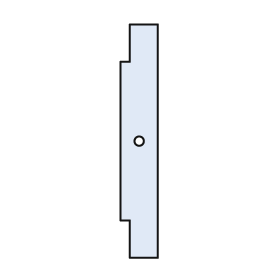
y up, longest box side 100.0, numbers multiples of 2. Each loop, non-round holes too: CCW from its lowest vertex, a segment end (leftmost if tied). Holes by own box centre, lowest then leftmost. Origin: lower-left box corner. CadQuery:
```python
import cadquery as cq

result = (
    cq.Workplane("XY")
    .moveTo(4.0, 0.0)
    .lineTo(16.0, 0.0)
    .lineTo(16.0, 100.0)
    .lineTo(4.0, 100.0)
    .lineTo(4.0, 84.0)
    .lineTo(0.0, 84.0)
    .lineTo(0.0, 16.0)
    .lineTo(4.0, 16.0)
    .close()
    .moveTo(8.0, 50.0)
    .circle(2.0)
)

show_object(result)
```